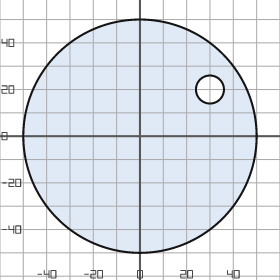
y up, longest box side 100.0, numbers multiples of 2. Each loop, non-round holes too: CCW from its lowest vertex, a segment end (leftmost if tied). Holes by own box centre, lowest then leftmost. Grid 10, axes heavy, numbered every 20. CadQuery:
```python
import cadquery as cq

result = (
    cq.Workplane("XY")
    .moveTo(0.0, 0.0)
    .circle(50.0)
    .moveTo(30.0, 20.0)
    .circle(6.0)
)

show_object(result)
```